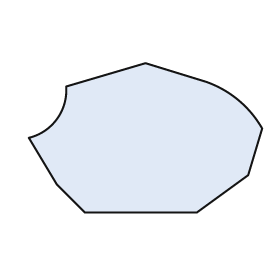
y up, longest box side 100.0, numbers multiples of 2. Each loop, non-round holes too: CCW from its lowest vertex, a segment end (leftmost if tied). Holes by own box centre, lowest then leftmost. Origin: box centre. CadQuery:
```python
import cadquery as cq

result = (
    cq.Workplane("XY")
    .moveTo(-26.0, -32.0)
    .lineTo(22.0, -32.0)
    .lineTo(44.0, -16.0)
    .lineTo(50.0, 4.0)
    .threePointArc((40.0, 16.0), (26.0, 24.0))
    .lineTo(0.0, 32.0)
    .lineTo(-34.0, 22.0)
    .threePointArc((-38.0, 8.0), (-50.0, 0.0))
    .lineTo(-38.0, -20.0)
    .close()
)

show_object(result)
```